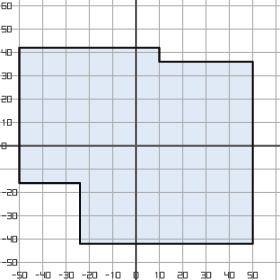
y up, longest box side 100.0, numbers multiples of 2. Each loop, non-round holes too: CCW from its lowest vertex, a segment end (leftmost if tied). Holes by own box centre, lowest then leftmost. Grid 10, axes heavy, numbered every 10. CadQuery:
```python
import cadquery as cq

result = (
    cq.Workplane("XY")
    .moveTo(-24.0, -42.0)
    .lineTo(50.0, -42.0)
    .lineTo(50.0, 36.0)
    .lineTo(10.0, 36.0)
    .lineTo(10.0, 42.0)
    .lineTo(-50.0, 42.0)
    .lineTo(-50.0, -16.0)
    .lineTo(-24.0, -16.0)
    .close()
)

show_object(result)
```